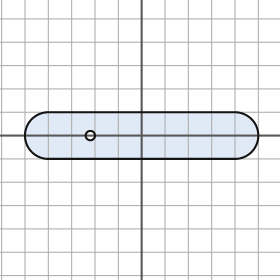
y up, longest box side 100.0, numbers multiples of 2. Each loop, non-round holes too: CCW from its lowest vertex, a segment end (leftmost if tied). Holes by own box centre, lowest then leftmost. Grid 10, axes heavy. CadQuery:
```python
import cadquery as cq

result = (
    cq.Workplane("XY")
    .moveTo(-40.0, -10.0)
    .lineTo(40.0, -10.0)
    .threePointArc((50.0, 0.0), (40.0, 10.0))
    .lineTo(-40.0, 10.0)
    .threePointArc((-50.0, 0.0), (-40.0, -10.0))
    .close()
    .moveTo(-22.0, 0.0)
    .circle(2.0)
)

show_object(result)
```